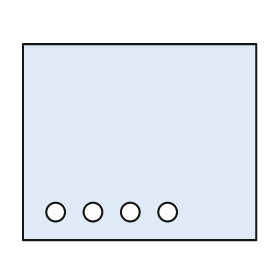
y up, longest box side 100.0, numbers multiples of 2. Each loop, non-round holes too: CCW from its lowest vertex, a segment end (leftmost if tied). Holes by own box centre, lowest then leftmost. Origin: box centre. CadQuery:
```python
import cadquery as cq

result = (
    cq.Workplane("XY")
    .moveTo(-50.0, -42.0)
    .lineTo(50.0, -42.0)
    .lineTo(50.0, 42.0)
    .lineTo(-50.0, 42.0)
    .close()
    .moveTo(-36.0, -30.0)
    .circle(4.0)
    .moveTo(-20.0, -30.0)
    .circle(4.0)
    .moveTo(-4.0, -30.0)
    .circle(4.0)
    .moveTo(12.0, -30.0)
    .circle(4.0)
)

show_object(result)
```